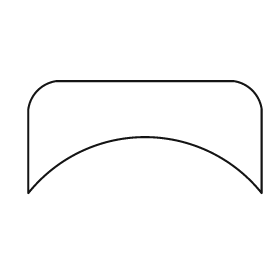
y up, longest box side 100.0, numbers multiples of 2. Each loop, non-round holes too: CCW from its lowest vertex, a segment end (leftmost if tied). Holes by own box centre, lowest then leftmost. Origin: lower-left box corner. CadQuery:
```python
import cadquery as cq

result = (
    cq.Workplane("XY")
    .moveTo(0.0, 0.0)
    .threePointArc((50.0, 24.0), (100.0, 0.0))
    .lineTo(100.0, 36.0)
    .threePointArc((96.0, 44.0), (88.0, 48.0))
    .lineTo(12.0, 48.0)
    .threePointArc((4.0, 44.0), (0.0, 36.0))
    .close()
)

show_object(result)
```